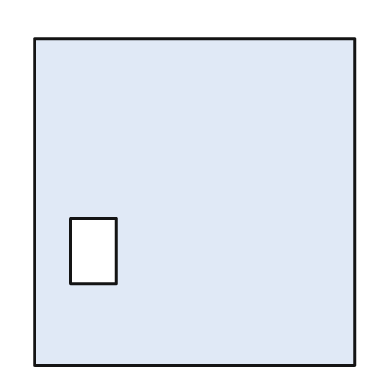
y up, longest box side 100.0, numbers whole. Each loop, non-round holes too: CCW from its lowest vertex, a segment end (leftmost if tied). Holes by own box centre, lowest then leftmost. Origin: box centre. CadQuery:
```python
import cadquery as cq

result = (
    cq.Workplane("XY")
    .moveTo(-49.0, -50.0)
    .lineTo(49.0, -50.0)
    .lineTo(49.0, 50.0)
    .lineTo(-49.0, 50.0)
    .close()
    .moveTo(-38.0, -25.0)
    .lineTo(-24.0, -25.0)
    .lineTo(-24.0, -5.0)
    .lineTo(-38.0, -5.0)
    .close()
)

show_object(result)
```